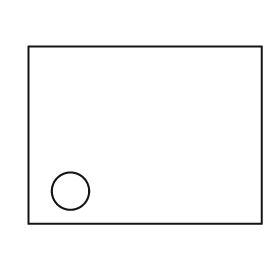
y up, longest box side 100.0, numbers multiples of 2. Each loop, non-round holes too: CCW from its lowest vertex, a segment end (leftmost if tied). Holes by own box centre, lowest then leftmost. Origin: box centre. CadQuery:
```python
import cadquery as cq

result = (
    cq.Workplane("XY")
    .moveTo(-50.0, -38.0)
    .lineTo(50.0, -38.0)
    .lineTo(50.0, 38.0)
    .lineTo(-50.0, 38.0)
    .close()
    .moveTo(-32.0, -24.0)
    .circle(8.0)
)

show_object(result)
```